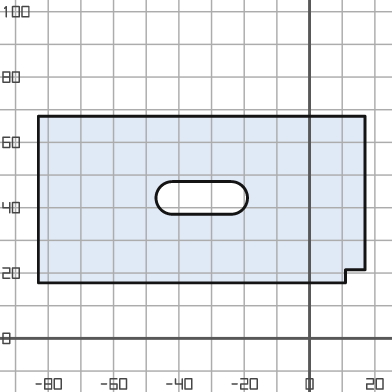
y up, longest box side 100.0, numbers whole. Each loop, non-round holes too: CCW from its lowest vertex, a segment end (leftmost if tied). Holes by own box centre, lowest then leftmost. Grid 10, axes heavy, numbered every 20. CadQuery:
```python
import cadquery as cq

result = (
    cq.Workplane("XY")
    .moveTo(-83.0, 17.0)
    .lineTo(11.0, 17.0)
    .lineTo(11.0, 21.0)
    .lineTo(17.0, 21.0)
    .lineTo(17.0, 68.0)
    .lineTo(-83.0, 68.0)
    .close()
    .moveTo(-42.0, 38.0)
    .lineTo(-24.0, 38.0)
    .threePointArc((-19.0, 43.0), (-24.0, 48.0))
    .lineTo(-42.0, 48.0)
    .threePointArc((-47.0, 43.0), (-42.0, 38.0))
    .close()
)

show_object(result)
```